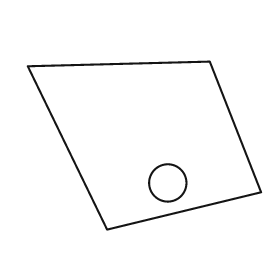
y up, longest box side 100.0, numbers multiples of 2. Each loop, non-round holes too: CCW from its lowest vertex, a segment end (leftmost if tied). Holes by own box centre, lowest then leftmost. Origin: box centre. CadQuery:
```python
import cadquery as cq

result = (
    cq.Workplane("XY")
    .moveTo(-16.0, -36.0)
    .lineTo(50.0, -20.0)
    .lineTo(28.0, 36.0)
    .lineTo(-50.0, 34.0)
    .close()
    .moveTo(10.0, -16.0)
    .circle(8.0)
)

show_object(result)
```